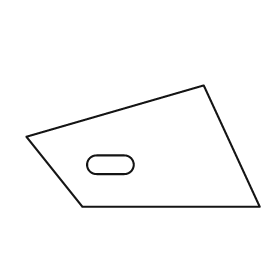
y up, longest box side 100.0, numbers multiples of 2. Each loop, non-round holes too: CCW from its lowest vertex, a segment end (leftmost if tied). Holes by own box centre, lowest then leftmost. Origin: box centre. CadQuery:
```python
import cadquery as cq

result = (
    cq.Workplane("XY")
    .moveTo(-26.0, -26.0)
    .lineTo(50.0, -26.0)
    .lineTo(26.0, 26.0)
    .lineTo(-50.0, 4.0)
    .close()
    .moveTo(-20.0, -12.0)
    .lineTo(-8.0, -12.0)
    .threePointArc((-4.0, -8.0), (-8.0, -4.0))
    .lineTo(-20.0, -4.0)
    .threePointArc((-24.0, -8.0), (-20.0, -12.0))
    .close()
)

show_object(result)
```